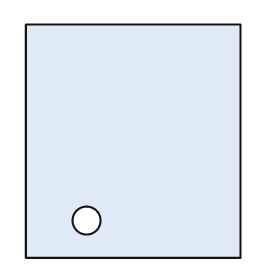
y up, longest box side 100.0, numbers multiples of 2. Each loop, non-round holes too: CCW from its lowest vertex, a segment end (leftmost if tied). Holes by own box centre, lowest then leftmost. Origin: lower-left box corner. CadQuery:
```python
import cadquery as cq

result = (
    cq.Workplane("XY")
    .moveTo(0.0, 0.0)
    .lineTo(92.0, 0.0)
    .lineTo(92.0, 100.0)
    .lineTo(0.0, 100.0)
    .close()
    .moveTo(26.0, 16.0)
    .circle(6.0)
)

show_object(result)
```